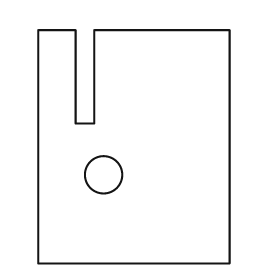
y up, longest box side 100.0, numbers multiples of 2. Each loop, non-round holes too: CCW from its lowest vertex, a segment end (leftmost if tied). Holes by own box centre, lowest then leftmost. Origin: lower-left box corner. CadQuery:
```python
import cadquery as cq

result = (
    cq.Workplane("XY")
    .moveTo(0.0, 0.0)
    .lineTo(82.0, 0.0)
    .lineTo(82.0, 100.0)
    .lineTo(24.0, 100.0)
    .lineTo(24.0, 60.0)
    .lineTo(16.0, 60.0)
    .lineTo(16.0, 100.0)
    .lineTo(0.0, 100.0)
    .close()
    .moveTo(28.0, 38.0)
    .circle(8.0)
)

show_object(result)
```